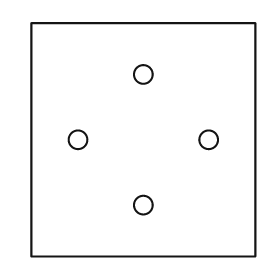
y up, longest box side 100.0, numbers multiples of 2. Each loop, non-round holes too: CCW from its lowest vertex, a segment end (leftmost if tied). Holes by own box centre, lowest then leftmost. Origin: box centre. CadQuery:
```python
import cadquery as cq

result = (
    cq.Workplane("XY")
    .moveTo(-48.0, -50.0)
    .lineTo(48.0, -50.0)
    .lineTo(48.0, 50.0)
    .lineTo(-48.0, 50.0)
    .close()
    .moveTo(0.0, -28.0)
    .circle(4.0)
    .moveTo(-28.0, 0.0)
    .circle(4.0)
    .moveTo(28.0, 0.0)
    .circle(4.0)
    .moveTo(0.0, 28.0)
    .circle(4.0)
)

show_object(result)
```